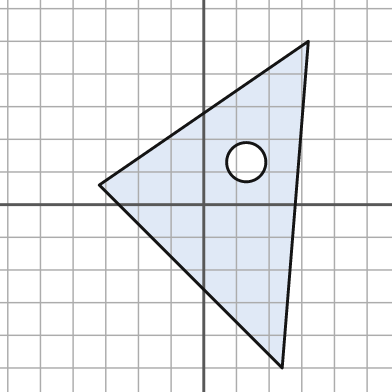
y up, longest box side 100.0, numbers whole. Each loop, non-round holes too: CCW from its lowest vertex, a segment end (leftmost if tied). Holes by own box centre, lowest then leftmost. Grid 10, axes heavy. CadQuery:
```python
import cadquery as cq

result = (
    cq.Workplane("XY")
    .moveTo(24.0, -50.0)
    .lineTo(32.0, 50.0)
    .lineTo(-32.0, 6.0)
    .close()
    .moveTo(13.0, 13.0)
    .circle(6.0)
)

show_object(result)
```